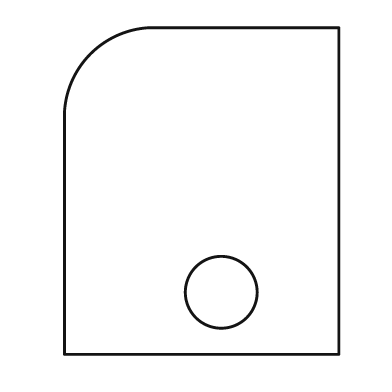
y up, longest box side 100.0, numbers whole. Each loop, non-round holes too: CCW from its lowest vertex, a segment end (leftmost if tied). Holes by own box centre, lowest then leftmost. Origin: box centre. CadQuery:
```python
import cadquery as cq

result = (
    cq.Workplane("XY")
    .moveTo(-42.0, -50.0)
    .lineTo(42.0, -50.0)
    .lineTo(42.0, 50.0)
    .lineTo(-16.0, 50.0)
    .threePointArc((-34.0, 42.0), (-42.0, 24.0))
    .close()
    .moveTo(6.0, -31.0)
    .circle(11.0)
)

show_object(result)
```